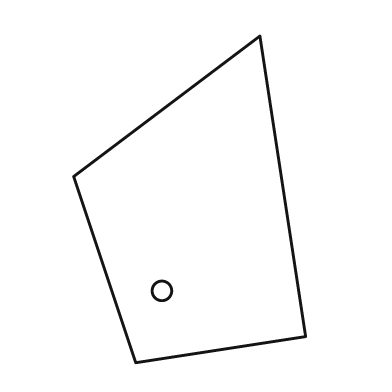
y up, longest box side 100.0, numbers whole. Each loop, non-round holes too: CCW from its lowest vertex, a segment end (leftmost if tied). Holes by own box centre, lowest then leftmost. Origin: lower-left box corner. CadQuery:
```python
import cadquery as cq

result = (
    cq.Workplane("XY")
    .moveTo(19.0, 0.0)
    .lineTo(71.0, 8.0)
    .lineTo(57.0, 100.0)
    .lineTo(0.0, 57.0)
    .close()
    .moveTo(27.0, 22.0)
    .circle(3.0)
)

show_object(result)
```